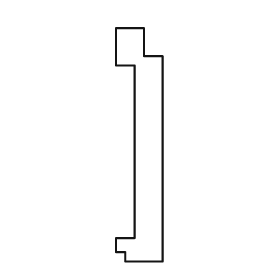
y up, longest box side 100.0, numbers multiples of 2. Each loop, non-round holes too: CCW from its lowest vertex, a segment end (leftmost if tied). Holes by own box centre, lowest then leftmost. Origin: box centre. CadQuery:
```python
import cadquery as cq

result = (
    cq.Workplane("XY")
    .moveTo(-6.0, -50.0)
    .lineTo(10.0, -50.0)
    .lineTo(10.0, 38.0)
    .lineTo(2.0, 38.0)
    .lineTo(2.0, 50.0)
    .lineTo(-10.0, 50.0)
    .lineTo(-10.0, 34.0)
    .lineTo(-2.0, 34.0)
    .lineTo(-2.0, -40.0)
    .lineTo(-10.0, -40.0)
    .lineTo(-10.0, -46.0)
    .lineTo(-6.0, -46.0)
    .close()
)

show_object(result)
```